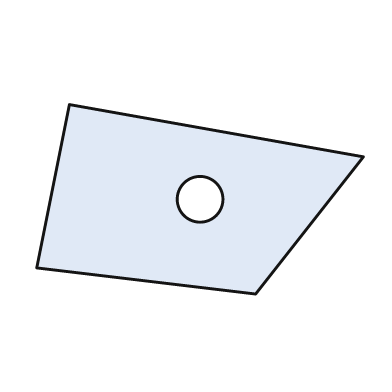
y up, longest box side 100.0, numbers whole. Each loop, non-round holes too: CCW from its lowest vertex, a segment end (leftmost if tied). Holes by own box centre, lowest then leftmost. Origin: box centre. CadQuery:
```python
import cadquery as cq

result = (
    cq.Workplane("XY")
    .moveTo(17.0, -29.0)
    .lineTo(50.0, 13.0)
    .lineTo(-40.0, 29.0)
    .lineTo(-50.0, -21.0)
    .close()
    .moveTo(0.0, 0.0)
    .circle(7.0)
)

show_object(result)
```